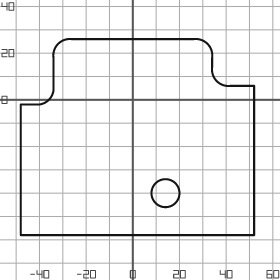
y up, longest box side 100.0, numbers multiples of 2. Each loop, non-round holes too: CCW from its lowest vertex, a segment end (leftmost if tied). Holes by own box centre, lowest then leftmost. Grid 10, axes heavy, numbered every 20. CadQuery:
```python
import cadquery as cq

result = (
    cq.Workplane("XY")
    .moveTo(-48.0, -58.0)
    .lineTo(52.0, -58.0)
    .lineTo(52.0, 6.0)
    .lineTo(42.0, 6.0)
    .threePointArc((36.0, 8.0), (34.0, 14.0))
    .lineTo(34.0, 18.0)
    .threePointArc((32.0, 24.0), (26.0, 26.0))
    .lineTo(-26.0, 26.0)
    .threePointArc((-32.0, 24.0), (-34.0, 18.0))
    .lineTo(-34.0, 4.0)
    .threePointArc((-36.0, 0.0), (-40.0, -2.0))
    .lineTo(-48.0, -2.0)
    .close()
    .moveTo(14.0, -40.0)
    .circle(6.0)
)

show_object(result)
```